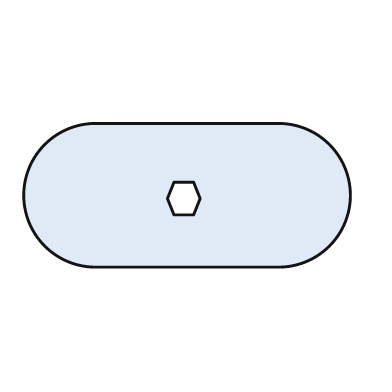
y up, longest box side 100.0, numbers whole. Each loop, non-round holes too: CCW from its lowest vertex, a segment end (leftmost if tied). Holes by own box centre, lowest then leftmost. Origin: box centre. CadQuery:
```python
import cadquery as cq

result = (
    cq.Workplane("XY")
    .moveTo(-28.0, -22.0)
    .lineTo(28.0, -22.0)
    .threePointArc((50.0, 0.0), (28.0, 22.0))
    .lineTo(-28.0, 22.0)
    .threePointArc((-50.0, 0.0), (-28.0, -22.0))
    .close()
    .moveTo(-4.0, -6.0)
    .lineTo(2.0, -6.0)
    .lineTo(4.0, -1.0)
    .lineTo(2.0, 4.0)
    .lineTo(-4.0, 4.0)
    .lineTo(-6.0, -1.0)
    .close()
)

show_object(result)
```